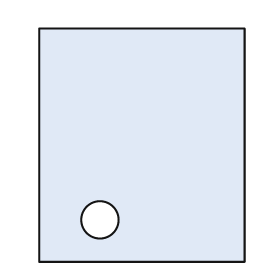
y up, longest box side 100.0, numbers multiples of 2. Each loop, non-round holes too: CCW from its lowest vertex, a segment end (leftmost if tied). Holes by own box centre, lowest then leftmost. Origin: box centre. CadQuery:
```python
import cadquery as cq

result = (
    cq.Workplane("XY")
    .moveTo(-44.0, -50.0)
    .lineTo(44.0, -50.0)
    .lineTo(44.0, 50.0)
    .lineTo(-44.0, 50.0)
    .close()
    .moveTo(-18.0, -32.0)
    .circle(8.0)
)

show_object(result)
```